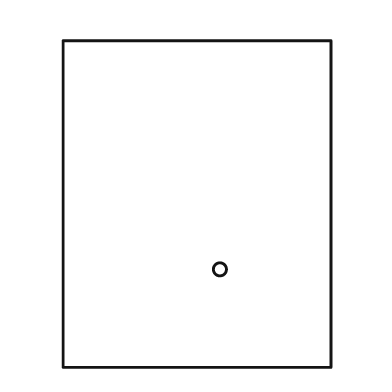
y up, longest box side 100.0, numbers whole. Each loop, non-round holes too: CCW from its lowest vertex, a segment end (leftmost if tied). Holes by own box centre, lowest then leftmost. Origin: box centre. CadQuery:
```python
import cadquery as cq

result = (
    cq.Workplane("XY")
    .moveTo(-41.0, -50.0)
    .lineTo(41.0, -50.0)
    .lineTo(41.0, 50.0)
    .lineTo(-41.0, 50.0)
    .close()
    .moveTo(7.0, -20.0)
    .circle(2.0)
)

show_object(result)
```